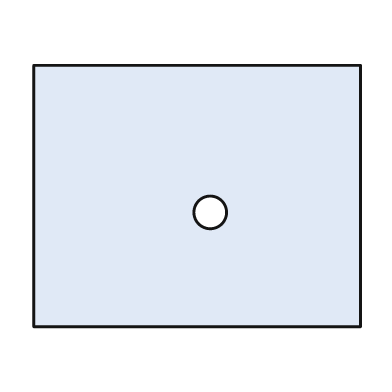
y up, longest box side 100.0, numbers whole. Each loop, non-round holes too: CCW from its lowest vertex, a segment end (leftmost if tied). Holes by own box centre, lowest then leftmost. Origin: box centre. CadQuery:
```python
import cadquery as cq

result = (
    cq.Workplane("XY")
    .moveTo(-50.0, -40.0)
    .lineTo(50.0, -40.0)
    .lineTo(50.0, 40.0)
    .lineTo(-50.0, 40.0)
    .close()
    .moveTo(4.0, -5.0)
    .circle(5.0)
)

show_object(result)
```